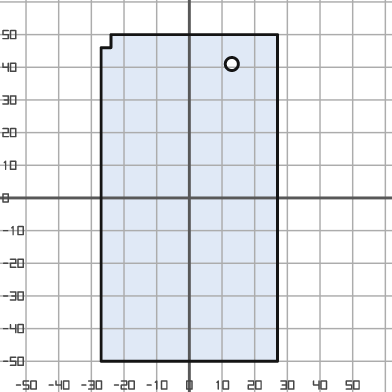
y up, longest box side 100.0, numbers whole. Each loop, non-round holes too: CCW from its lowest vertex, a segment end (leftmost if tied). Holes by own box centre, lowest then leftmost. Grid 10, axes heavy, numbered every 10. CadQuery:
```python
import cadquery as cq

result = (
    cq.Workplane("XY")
    .moveTo(-27.0, -50.0)
    .lineTo(27.0, -50.0)
    .lineTo(27.0, 50.0)
    .lineTo(-24.0, 50.0)
    .lineTo(-24.0, 46.0)
    .lineTo(-27.0, 46.0)
    .close()
    .moveTo(13.0, 41.0)
    .circle(2.0)
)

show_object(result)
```